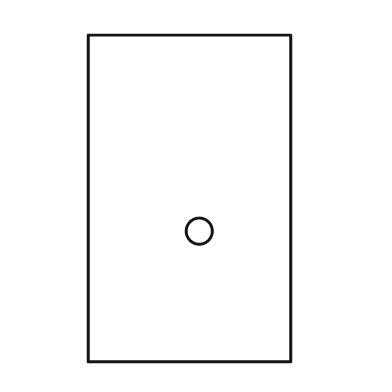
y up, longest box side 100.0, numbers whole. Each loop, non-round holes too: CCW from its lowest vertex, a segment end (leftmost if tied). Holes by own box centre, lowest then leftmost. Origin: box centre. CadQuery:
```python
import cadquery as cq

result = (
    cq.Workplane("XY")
    .moveTo(-31.0, -50.0)
    .lineTo(31.0, -50.0)
    .lineTo(31.0, 50.0)
    .lineTo(-31.0, 50.0)
    .close()
    .moveTo(3.0, -10.0)
    .circle(4.0)
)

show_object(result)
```